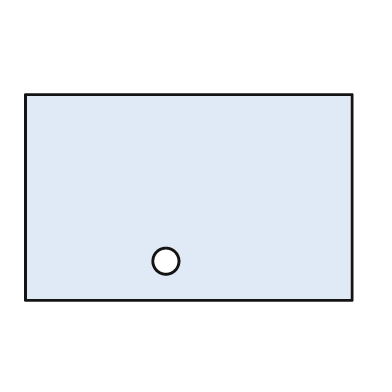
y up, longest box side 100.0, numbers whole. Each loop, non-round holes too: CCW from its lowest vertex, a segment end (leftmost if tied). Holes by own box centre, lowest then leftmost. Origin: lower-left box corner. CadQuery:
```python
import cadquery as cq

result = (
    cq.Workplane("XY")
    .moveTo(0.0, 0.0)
    .lineTo(100.0, 0.0)
    .lineTo(100.0, 63.0)
    .lineTo(0.0, 63.0)
    .close()
    .moveTo(43.0, 12.0)
    .circle(4.0)
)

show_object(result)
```